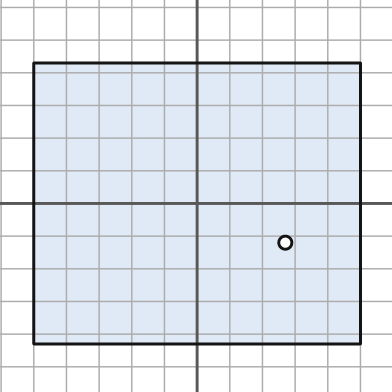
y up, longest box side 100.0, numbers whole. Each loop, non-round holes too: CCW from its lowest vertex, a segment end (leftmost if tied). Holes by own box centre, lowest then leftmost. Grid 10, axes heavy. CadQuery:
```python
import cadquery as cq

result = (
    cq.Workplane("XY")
    .moveTo(-50.0, -43.0)
    .lineTo(50.0, -43.0)
    .lineTo(50.0, 43.0)
    .lineTo(-50.0, 43.0)
    .close()
    .moveTo(27.0, -12.0)
    .circle(2.0)
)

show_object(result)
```